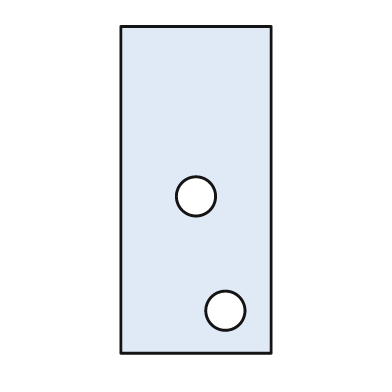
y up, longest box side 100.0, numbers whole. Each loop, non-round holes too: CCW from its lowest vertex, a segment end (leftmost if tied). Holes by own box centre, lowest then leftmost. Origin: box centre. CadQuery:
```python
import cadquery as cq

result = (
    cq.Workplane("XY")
    .moveTo(-23.0, -50.0)
    .lineTo(23.0, -50.0)
    .lineTo(23.0, 50.0)
    .lineTo(-23.0, 50.0)
    .close()
    .moveTo(9.0, -37.0)
    .circle(6.0)
    .moveTo(0.0, -2.0)
    .circle(6.0)
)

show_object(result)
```